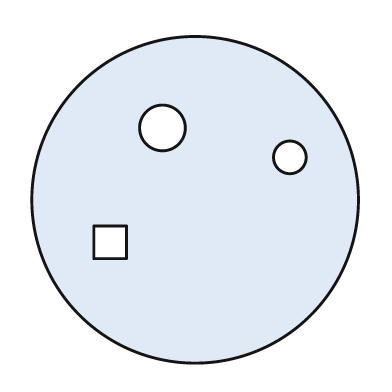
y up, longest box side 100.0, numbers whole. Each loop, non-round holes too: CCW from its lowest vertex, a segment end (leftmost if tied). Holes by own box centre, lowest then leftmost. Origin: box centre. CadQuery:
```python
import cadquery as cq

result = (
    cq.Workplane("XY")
    .moveTo(0.0, 0.0)
    .circle(50.0)
    .moveTo(-31.0, -18.0)
    .lineTo(-21.0, -18.0)
    .lineTo(-21.0, -8.0)
    .lineTo(-31.0, -8.0)
    .close()
    .moveTo(29.0, 13.0)
    .circle(5.0)
    .moveTo(-10.0, 22.0)
    .circle(7.0)
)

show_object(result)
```